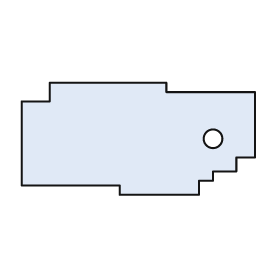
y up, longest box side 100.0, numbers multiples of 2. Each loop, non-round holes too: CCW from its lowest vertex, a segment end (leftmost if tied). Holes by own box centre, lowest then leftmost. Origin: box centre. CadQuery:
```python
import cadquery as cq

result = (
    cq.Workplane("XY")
    .moveTo(-8.0, -24.0)
    .lineTo(26.0, -24.0)
    .lineTo(26.0, -18.0)
    .lineTo(32.0, -18.0)
    .lineTo(32.0, -14.0)
    .lineTo(42.0, -14.0)
    .lineTo(42.0, -8.0)
    .lineTo(50.0, -8.0)
    .lineTo(50.0, 20.0)
    .lineTo(12.0, 20.0)
    .lineTo(12.0, 24.0)
    .lineTo(-38.0, 24.0)
    .lineTo(-38.0, 16.0)
    .lineTo(-50.0, 16.0)
    .lineTo(-50.0, -20.0)
    .lineTo(-8.0, -20.0)
    .close()
    .moveTo(32.0, 0.0)
    .circle(4.0)
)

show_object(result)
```